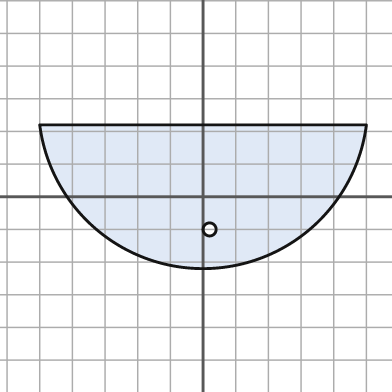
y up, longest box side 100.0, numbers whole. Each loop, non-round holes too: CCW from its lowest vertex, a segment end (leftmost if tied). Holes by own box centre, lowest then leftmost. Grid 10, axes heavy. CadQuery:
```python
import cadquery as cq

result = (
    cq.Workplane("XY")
    .moveTo(-50.0, 22.0)
    .threePointArc((0.0, -22.0), (50.0, 22.0))
    .close()
    .moveTo(2.0, -10.0)
    .circle(2.0)
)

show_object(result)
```